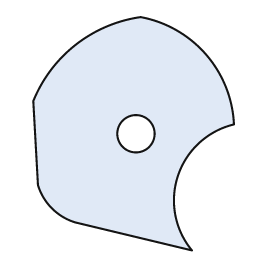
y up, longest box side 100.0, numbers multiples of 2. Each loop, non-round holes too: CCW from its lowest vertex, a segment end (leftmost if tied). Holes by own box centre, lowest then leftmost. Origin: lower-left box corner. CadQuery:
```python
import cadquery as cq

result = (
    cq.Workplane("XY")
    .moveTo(68.0, 0.0)
    .threePointArc((62.0, 32.0), (86.0, 54.0))
    .threePointArc((74.0, 84.0), (46.0, 100.0))
    .threePointArc((18.0, 88.0), (0.0, 64.0))
    .lineTo(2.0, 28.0)
    .threePointArc((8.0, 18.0), (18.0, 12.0))
    .close()
    .moveTo(44.0, 50.0)
    .circle(8.0)
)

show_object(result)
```